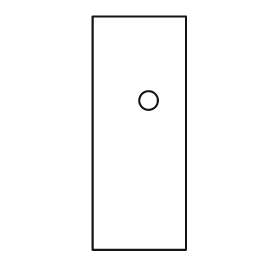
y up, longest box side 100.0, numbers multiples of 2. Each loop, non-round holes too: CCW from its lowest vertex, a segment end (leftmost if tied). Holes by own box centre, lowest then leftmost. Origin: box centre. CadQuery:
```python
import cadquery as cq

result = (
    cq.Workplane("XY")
    .moveTo(-20.0, -50.0)
    .lineTo(20.0, -50.0)
    .lineTo(20.0, 50.0)
    .lineTo(-20.0, 50.0)
    .close()
    .moveTo(4.0, 14.0)
    .circle(4.0)
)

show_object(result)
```